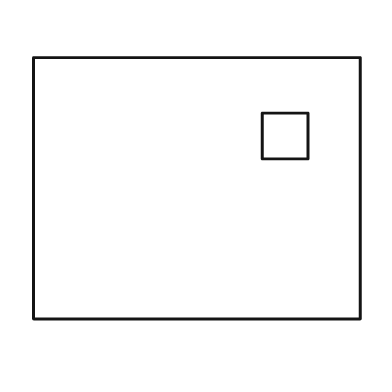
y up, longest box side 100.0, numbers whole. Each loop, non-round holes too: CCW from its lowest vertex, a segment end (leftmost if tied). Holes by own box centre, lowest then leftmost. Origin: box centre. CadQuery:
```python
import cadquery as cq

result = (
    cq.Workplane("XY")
    .moveTo(-50.0, -40.0)
    .lineTo(50.0, -40.0)
    .lineTo(50.0, 40.0)
    .lineTo(-50.0, 40.0)
    .close()
    .moveTo(20.0, 9.0)
    .lineTo(34.0, 9.0)
    .lineTo(34.0, 23.0)
    .lineTo(20.0, 23.0)
    .close()
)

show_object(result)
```